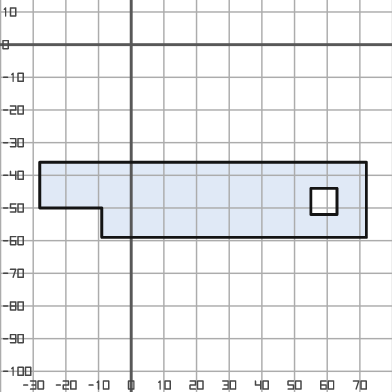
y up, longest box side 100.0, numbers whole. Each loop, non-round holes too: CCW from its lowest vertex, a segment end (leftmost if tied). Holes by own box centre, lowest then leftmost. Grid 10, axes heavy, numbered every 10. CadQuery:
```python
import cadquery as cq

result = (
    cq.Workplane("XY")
    .moveTo(-9.0, -59.0)
    .lineTo(72.0, -59.0)
    .lineTo(72.0, -36.0)
    .lineTo(-28.0, -36.0)
    .lineTo(-28.0, -50.0)
    .lineTo(-9.0, -50.0)
    .close()
    .moveTo(55.0, -52.0)
    .lineTo(63.0, -52.0)
    .lineTo(63.0, -44.0)
    .lineTo(55.0, -44.0)
    .close()
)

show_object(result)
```